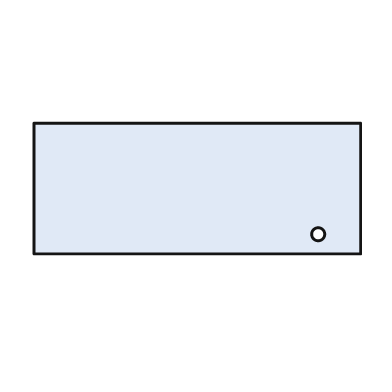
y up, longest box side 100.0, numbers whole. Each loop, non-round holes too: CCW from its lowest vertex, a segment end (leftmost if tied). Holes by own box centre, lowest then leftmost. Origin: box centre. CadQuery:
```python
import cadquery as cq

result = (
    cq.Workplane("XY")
    .moveTo(-50.0, -20.0)
    .lineTo(50.0, -20.0)
    .lineTo(50.0, 20.0)
    .lineTo(-50.0, 20.0)
    .close()
    .moveTo(37.0, -14.0)
    .circle(2.0)
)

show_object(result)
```